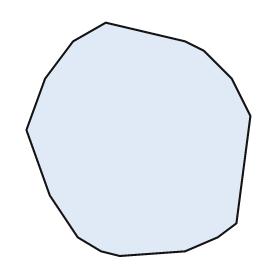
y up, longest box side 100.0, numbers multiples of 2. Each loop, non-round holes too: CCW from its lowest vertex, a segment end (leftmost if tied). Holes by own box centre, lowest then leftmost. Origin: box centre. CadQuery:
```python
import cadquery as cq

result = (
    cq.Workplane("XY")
    .moveTo(-8.0, -50.0)
    .lineTo(20.0, -48.0)
    .lineTo(34.0, -42.0)
    .lineTo(42.0, -36.0)
    .lineTo(48.0, 10.0)
    .lineTo(40.0, 26.0)
    .lineTo(28.0, 38.0)
    .lineTo(20.0, 42.0)
    .lineTo(-14.0, 50.0)
    .lineTo(-28.0, 42.0)
    .lineTo(-40.0, 26.0)
    .lineTo(-48.0, 4.0)
    .lineTo(-38.0, -24.0)
    .lineTo(-26.0, -42.0)
    .lineTo(-16.0, -48.0)
    .close()
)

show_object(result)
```